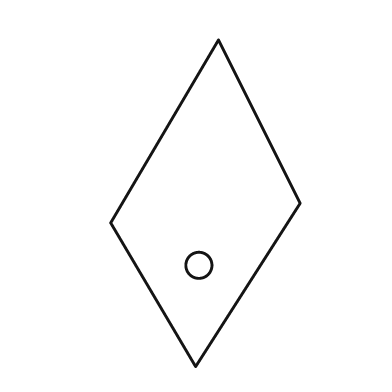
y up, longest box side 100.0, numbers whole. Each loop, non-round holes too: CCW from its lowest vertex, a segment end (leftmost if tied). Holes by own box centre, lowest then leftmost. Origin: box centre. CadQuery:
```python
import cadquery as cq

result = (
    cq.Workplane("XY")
    .moveTo(-3.0, -50.0)
    .lineTo(29.0, 0.0)
    .lineTo(4.0, 50.0)
    .lineTo(-29.0, -6.0)
    .close()
    .moveTo(-2.0, -19.0)
    .circle(4.0)
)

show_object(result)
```